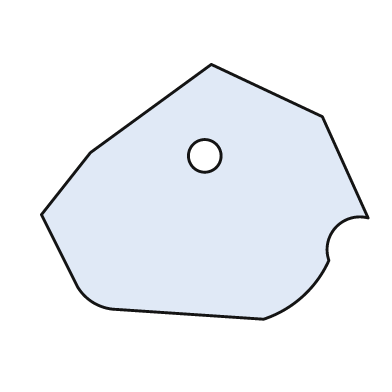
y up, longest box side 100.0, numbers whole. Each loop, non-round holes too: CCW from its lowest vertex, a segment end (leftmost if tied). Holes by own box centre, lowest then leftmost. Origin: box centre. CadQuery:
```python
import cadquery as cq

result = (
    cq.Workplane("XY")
    .moveTo(18.0, -39.0)
    .threePointArc((30.0, -32.0), (38.0, -21.0))
    .threePointArc((40.0, -11.0), (50.0, -8.0))
    .lineTo(36.0, 23.0)
    .lineTo(2.0, 39.0)
    .lineTo(-35.0, 12.0)
    .lineTo(-50.0, -7.0)
    .lineTo(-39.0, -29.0)
    .threePointArc((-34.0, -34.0), (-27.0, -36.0))
    .close()
    .moveTo(0.0, 11.0)
    .circle(5.0)
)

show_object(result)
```